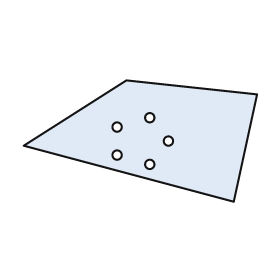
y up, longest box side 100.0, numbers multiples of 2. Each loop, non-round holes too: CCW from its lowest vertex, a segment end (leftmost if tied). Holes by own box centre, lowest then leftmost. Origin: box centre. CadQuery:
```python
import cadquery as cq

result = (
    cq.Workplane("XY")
    .moveTo(40.0, -26.0)
    .lineTo(50.0, 20.0)
    .lineTo(-6.0, 26.0)
    .lineTo(-50.0, -2.0)
    .close()
    .moveTo(4.0, -10.0)
    .circle(2.0)
    .moveTo(-10.0, -6.0)
    .circle(2.0)
    .moveTo(12.0, 0.0)
    .circle(2.0)
    .moveTo(-10.0, 6.0)
    .circle(2.0)
    .moveTo(4.0, 10.0)
    .circle(2.0)
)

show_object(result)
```